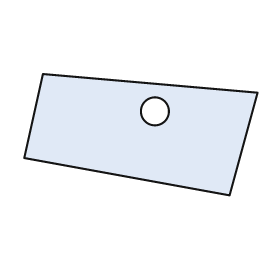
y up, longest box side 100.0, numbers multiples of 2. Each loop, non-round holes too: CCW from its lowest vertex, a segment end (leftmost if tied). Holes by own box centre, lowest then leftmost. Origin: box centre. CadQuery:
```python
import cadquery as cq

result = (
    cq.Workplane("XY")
    .moveTo(38.0, -26.0)
    .lineTo(50.0, 18.0)
    .lineTo(-42.0, 26.0)
    .lineTo(-50.0, -10.0)
    .close()
    .moveTo(6.0, 10.0)
    .circle(6.0)
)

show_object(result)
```